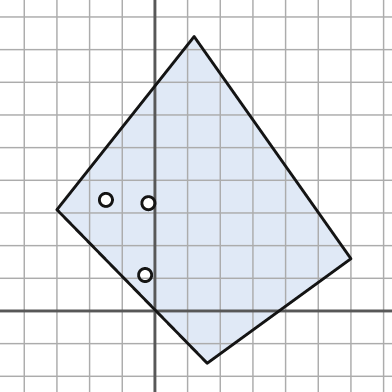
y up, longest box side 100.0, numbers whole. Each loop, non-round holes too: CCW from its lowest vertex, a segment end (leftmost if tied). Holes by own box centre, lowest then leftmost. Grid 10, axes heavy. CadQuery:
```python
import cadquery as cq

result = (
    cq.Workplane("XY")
    .moveTo(16.0, -16.0)
    .lineTo(60.0, 16.0)
    .lineTo(12.0, 84.0)
    .lineTo(-30.0, 31.0)
    .close()
    .moveTo(-3.0, 11.0)
    .circle(2.0)
    .moveTo(-2.0, 33.0)
    .circle(2.0)
    .moveTo(-15.0, 34.0)
    .circle(2.0)
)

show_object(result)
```